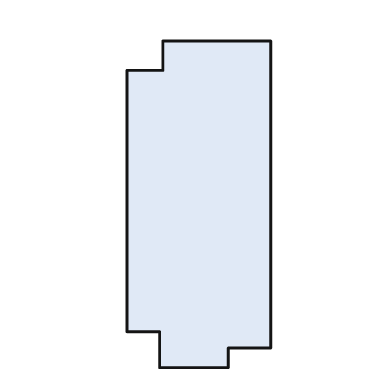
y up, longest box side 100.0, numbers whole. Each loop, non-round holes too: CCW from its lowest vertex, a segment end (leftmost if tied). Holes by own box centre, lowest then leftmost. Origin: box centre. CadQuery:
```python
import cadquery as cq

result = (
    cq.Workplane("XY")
    .moveTo(-12.0, -50.0)
    .lineTo(9.0, -50.0)
    .lineTo(9.0, -44.0)
    .lineTo(22.0, -44.0)
    .lineTo(22.0, 50.0)
    .lineTo(-11.0, 50.0)
    .lineTo(-11.0, 41.0)
    .lineTo(-22.0, 41.0)
    .lineTo(-22.0, -39.0)
    .lineTo(-12.0, -39.0)
    .close()
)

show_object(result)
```